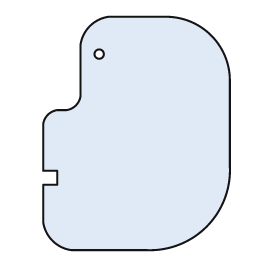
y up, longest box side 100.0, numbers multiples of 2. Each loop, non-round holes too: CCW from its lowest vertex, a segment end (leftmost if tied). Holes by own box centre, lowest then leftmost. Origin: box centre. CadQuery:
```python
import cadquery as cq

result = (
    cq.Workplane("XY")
    .moveTo(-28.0, -50.0)
    .lineTo(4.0, -50.0)
    .threePointArc((30.0, -40.0), (40.0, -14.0))
    .lineTo(40.0, 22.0)
    .threePointArc((32.0, 42.0), (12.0, 50.0))
    .lineTo(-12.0, 50.0)
    .threePointArc((-20.0, 46.0), (-24.0, 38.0))
    .lineTo(-24.0, 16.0)
    .threePointArc((-26.0, 12.0), (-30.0, 10.0))
    .lineTo(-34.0, 10.0)
    .threePointArc((-38.0, 8.0), (-40.0, 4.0))
    .lineTo(-40.0, -16.0)
    .lineTo(-34.0, -16.0)
    .lineTo(-34.0, -22.0)
    .lineTo(-40.0, -22.0)
    .lineTo(-40.0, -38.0)
    .threePointArc((-36.0, -46.0), (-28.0, -50.0))
    .close()
    .moveTo(-16.0, 34.0)
    .circle(2.0)
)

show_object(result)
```